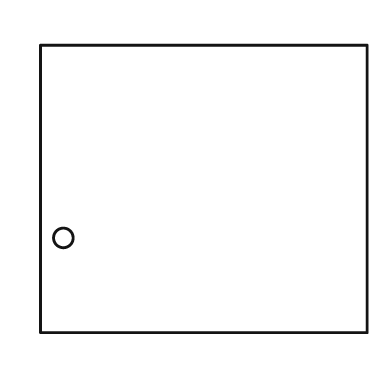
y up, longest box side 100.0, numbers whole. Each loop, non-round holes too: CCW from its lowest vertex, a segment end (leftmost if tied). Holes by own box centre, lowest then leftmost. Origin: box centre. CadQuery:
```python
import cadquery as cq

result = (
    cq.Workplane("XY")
    .moveTo(-50.0, -44.0)
    .lineTo(50.0, -44.0)
    .lineTo(50.0, 44.0)
    .lineTo(-50.0, 44.0)
    .close()
    .moveTo(-43.0, -15.0)
    .circle(3.0)
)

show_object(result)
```